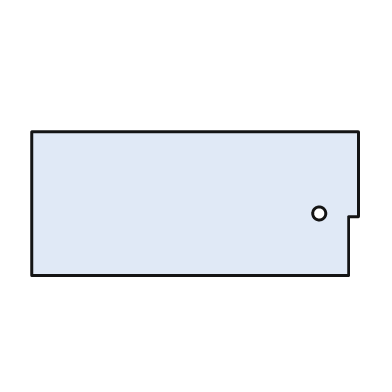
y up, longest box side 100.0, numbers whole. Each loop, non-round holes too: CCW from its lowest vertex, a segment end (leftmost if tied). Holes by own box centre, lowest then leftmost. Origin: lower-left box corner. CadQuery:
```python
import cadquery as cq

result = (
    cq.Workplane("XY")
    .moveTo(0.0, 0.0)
    .lineTo(97.0, 0.0)
    .lineTo(97.0, 18.0)
    .lineTo(100.0, 18.0)
    .lineTo(100.0, 44.0)
    .lineTo(0.0, 44.0)
    .close()
    .moveTo(88.0, 19.0)
    .circle(2.0)
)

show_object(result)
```